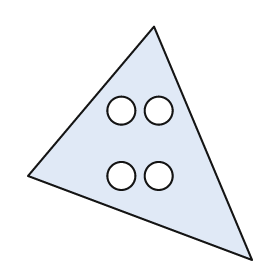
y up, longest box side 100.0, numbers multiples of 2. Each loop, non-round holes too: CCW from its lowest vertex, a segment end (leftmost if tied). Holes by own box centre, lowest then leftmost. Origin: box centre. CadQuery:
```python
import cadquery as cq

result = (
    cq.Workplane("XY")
    .moveTo(48.0, -50.0)
    .lineTo(6.0, 50.0)
    .lineTo(-48.0, -14.0)
    .close()
    .moveTo(-8.0, -14.0)
    .circle(6.0)
    .moveTo(8.0, -14.0)
    .circle(6.0)
    .moveTo(-8.0, 14.0)
    .circle(6.0)
    .moveTo(8.0, 14.0)
    .circle(6.0)
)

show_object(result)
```